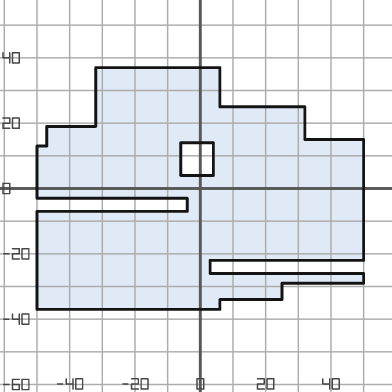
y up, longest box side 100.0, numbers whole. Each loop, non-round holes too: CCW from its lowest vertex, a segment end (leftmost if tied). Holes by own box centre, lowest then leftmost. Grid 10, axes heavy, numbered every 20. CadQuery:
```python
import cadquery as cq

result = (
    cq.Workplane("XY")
    .moveTo(-50.0, -37.0)
    .lineTo(6.0, -37.0)
    .lineTo(6.0, -34.0)
    .lineTo(25.0, -34.0)
    .lineTo(25.0, -29.0)
    .lineTo(50.0, -29.0)
    .lineTo(50.0, -26.0)
    .lineTo(3.0, -26.0)
    .lineTo(3.0, -22.0)
    .lineTo(50.0, -22.0)
    .lineTo(50.0, 15.0)
    .lineTo(32.0, 15.0)
    .lineTo(32.0, 25.0)
    .lineTo(6.0, 25.0)
    .lineTo(6.0, 37.0)
    .lineTo(-32.0, 37.0)
    .lineTo(-32.0, 19.0)
    .lineTo(-47.0, 19.0)
    .lineTo(-47.0, 13.0)
    .lineTo(-50.0, 13.0)
    .lineTo(-50.0, -3.0)
    .lineTo(-4.0, -3.0)
    .lineTo(-4.0, -7.0)
    .lineTo(-50.0, -7.0)
    .close()
    .moveTo(-6.0, 4.0)
    .lineTo(4.0, 4.0)
    .lineTo(4.0, 14.0)
    .lineTo(-6.0, 14.0)
    .close()
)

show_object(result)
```